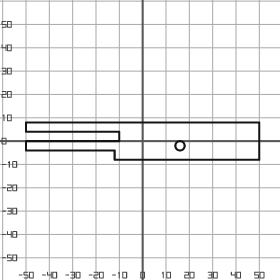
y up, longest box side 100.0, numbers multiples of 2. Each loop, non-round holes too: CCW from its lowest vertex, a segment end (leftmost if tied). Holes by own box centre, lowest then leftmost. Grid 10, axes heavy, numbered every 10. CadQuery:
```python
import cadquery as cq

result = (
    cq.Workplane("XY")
    .moveTo(-12.0, -8.0)
    .lineTo(50.0, -8.0)
    .lineTo(50.0, 8.0)
    .lineTo(-50.0, 8.0)
    .lineTo(-50.0, 4.0)
    .lineTo(-10.0, 4.0)
    .lineTo(-10.0, 0.0)
    .lineTo(-50.0, 0.0)
    .lineTo(-50.0, -4.0)
    .lineTo(-12.0, -4.0)
    .close()
    .moveTo(16.0, -2.0)
    .circle(2.0)
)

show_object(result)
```